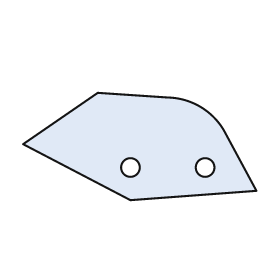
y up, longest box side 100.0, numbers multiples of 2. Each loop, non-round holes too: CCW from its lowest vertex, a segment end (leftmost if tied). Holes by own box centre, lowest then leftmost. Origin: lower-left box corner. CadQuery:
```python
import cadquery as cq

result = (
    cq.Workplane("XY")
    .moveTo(46.0, 0.0)
    .lineTo(100.0, 4.0)
    .lineTo(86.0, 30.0)
    .threePointArc((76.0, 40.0), (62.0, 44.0))
    .lineTo(32.0, 46.0)
    .lineTo(0.0, 24.0)
    .close()
    .moveTo(46.0, 14.0)
    .circle(4.0)
    .moveTo(78.0, 14.0)
    .circle(4.0)
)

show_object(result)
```